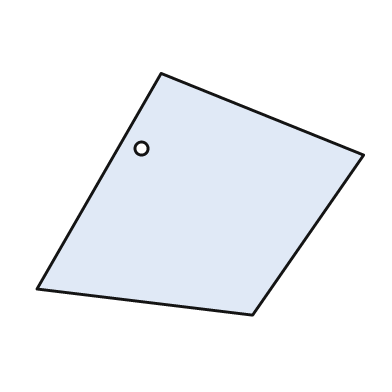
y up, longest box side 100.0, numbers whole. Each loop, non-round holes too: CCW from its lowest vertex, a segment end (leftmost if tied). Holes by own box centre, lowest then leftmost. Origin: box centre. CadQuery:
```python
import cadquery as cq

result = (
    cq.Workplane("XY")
    .moveTo(16.0, -37.0)
    .lineTo(50.0, 12.0)
    .lineTo(-12.0, 37.0)
    .lineTo(-50.0, -29.0)
    .close()
    .moveTo(-18.0, 14.0)
    .circle(2.0)
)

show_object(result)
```